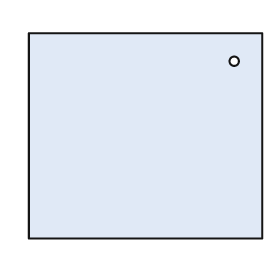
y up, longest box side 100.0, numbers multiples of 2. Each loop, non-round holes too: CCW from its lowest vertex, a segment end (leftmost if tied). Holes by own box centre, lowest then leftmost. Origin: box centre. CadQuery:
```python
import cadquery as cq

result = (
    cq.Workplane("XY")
    .moveTo(-50.0, -44.0)
    .lineTo(50.0, -44.0)
    .lineTo(50.0, 44.0)
    .lineTo(-50.0, 44.0)
    .close()
    .moveTo(38.0, 32.0)
    .circle(2.0)
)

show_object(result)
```